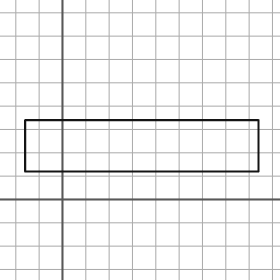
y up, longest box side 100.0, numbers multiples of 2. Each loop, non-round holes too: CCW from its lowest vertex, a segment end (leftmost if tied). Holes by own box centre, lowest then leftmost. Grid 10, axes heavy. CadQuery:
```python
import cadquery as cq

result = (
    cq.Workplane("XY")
    .moveTo(-16.0, 12.0)
    .lineTo(84.0, 12.0)
    .lineTo(84.0, 34.0)
    .lineTo(-16.0, 34.0)
    .close()
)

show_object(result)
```